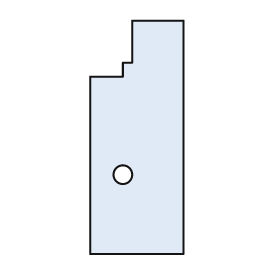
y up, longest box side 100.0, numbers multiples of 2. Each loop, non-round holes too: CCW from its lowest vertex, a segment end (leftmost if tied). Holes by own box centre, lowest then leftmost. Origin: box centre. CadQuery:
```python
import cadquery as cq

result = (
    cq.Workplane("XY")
    .moveTo(-20.0, -50.0)
    .lineTo(20.0, -50.0)
    .lineTo(20.0, 50.0)
    .lineTo(-2.0, 50.0)
    .lineTo(-2.0, 32.0)
    .lineTo(-6.0, 32.0)
    .lineTo(-6.0, 26.0)
    .lineTo(-20.0, 26.0)
    .close()
    .moveTo(-6.0, -16.0)
    .circle(4.0)
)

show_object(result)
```